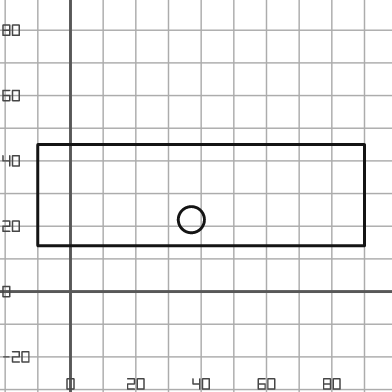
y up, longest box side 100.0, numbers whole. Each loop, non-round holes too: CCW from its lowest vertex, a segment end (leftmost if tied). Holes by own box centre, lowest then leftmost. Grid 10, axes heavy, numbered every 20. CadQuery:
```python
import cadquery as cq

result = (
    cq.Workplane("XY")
    .moveTo(-10.0, 14.0)
    .lineTo(90.0, 14.0)
    .lineTo(90.0, 45.0)
    .lineTo(-10.0, 45.0)
    .close()
    .moveTo(37.0, 22.0)
    .circle(4.0)
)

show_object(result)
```